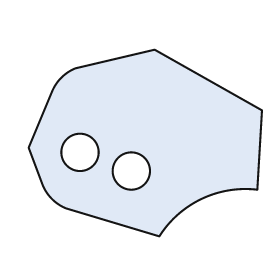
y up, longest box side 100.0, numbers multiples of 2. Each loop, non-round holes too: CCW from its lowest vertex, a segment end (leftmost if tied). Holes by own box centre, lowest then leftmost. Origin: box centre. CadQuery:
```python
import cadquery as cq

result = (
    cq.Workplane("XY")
    .moveTo(6.0, -40.0)
    .threePointArc((24.0, -24.0), (48.0, -20.0))
    .lineTo(50.0, 14.0)
    .lineTo(4.0, 40.0)
    .lineTo(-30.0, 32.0)
    .threePointArc((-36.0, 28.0), (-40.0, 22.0))
    .lineTo(-50.0, -2.0)
    .lineTo(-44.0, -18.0)
    .threePointArc((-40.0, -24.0), (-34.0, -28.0))
    .close()
    .moveTo(-6.0, -12.0)
    .circle(8.0)
    .moveTo(-28.0, -4.0)
    .circle(8.0)
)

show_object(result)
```